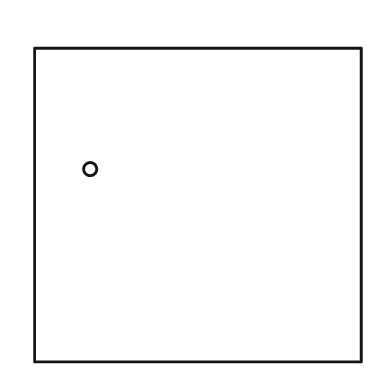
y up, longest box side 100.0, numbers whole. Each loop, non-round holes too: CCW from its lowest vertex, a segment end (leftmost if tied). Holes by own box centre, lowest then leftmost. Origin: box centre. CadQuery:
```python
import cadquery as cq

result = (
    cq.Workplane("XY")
    .moveTo(-50.0, -48.0)
    .lineTo(50.0, -48.0)
    .lineTo(50.0, 48.0)
    .lineTo(-50.0, 48.0)
    .close()
    .moveTo(-33.0, 11.0)
    .circle(2.0)
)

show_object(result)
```